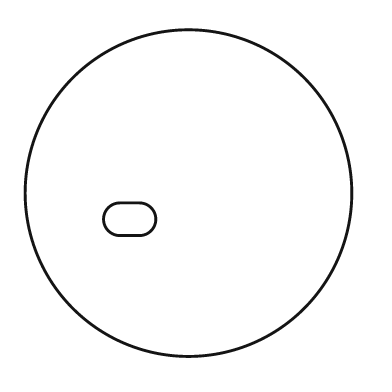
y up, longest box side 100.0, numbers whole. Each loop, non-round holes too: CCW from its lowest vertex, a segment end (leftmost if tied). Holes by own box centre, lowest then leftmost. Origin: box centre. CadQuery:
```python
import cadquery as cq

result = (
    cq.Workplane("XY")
    .moveTo(0.0, 0.0)
    .circle(50.0)
    .moveTo(-21.0, -13.0)
    .lineTo(-15.0, -13.0)
    .threePointArc((-10.0, -8.0), (-15.0, -3.0))
    .lineTo(-21.0, -3.0)
    .threePointArc((-26.0, -8.0), (-21.0, -13.0))
    .close()
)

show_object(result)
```